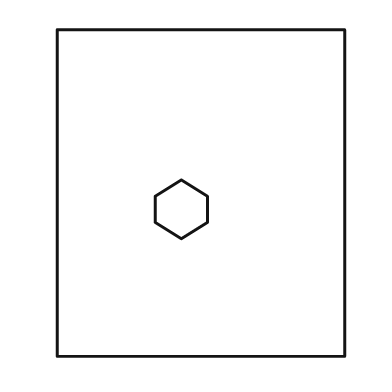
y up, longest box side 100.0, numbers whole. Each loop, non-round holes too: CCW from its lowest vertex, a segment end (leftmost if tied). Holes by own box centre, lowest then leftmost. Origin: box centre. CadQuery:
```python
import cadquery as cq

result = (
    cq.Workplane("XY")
    .moveTo(-44.0, -50.0)
    .lineTo(44.0, -50.0)
    .lineTo(44.0, 50.0)
    .lineTo(-44.0, 50.0)
    .close()
    .moveTo(-6.0, -14.0)
    .lineTo(2.0, -9.0)
    .lineTo(2.0, -1.0)
    .lineTo(-6.0, 4.0)
    .lineTo(-14.0, -1.0)
    .lineTo(-14.0, -9.0)
    .close()
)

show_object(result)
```